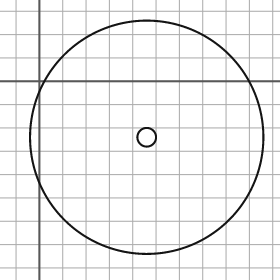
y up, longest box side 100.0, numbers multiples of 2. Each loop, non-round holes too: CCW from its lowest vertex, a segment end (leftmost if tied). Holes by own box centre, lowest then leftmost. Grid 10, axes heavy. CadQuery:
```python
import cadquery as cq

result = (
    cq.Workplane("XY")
    .moveTo(46.0, -24.0)
    .circle(50.0)
    .moveTo(46.0, -24.0)
    .circle(4.0)
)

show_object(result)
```